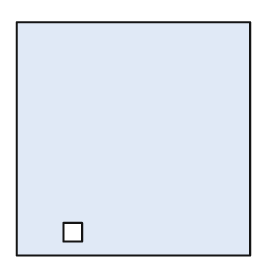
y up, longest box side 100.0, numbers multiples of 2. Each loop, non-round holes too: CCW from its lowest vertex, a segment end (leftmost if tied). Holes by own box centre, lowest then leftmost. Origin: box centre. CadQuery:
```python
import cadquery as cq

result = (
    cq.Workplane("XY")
    .moveTo(-50.0, -50.0)
    .lineTo(50.0, -50.0)
    .lineTo(50.0, 50.0)
    .lineTo(-50.0, 50.0)
    .close()
    .moveTo(-30.0, -44.0)
    .lineTo(-22.0, -44.0)
    .lineTo(-22.0, -36.0)
    .lineTo(-30.0, -36.0)
    .close()
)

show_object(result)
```